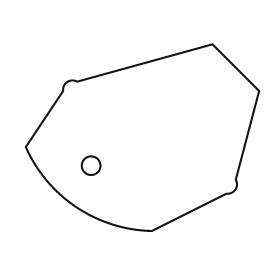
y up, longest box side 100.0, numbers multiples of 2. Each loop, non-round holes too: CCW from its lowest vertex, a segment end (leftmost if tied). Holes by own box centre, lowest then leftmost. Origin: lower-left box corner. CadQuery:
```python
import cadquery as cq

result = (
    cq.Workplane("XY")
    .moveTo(54.0, 0.0)
    .lineTo(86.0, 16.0)
    .threePointArc((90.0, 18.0), (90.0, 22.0))
    .lineTo(100.0, 60.0)
    .lineTo(80.0, 80.0)
    .lineTo(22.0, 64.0)
    .threePointArc((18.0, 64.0), (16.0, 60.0))
    .lineTo(0.0, 36.0)
    .threePointArc((22.0, 10.0), (54.0, 0.0))
    .close()
    .moveTo(28.0, 28.0)
    .circle(4.0)
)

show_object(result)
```